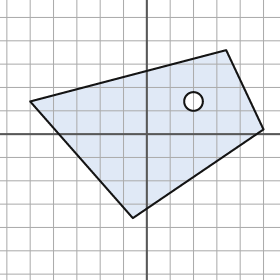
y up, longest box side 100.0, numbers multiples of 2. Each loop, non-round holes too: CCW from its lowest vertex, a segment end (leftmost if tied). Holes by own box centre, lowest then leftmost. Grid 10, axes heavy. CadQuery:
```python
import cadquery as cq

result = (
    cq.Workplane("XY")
    .moveTo(-6.0, -36.0)
    .lineTo(50.0, 2.0)
    .lineTo(34.0, 36.0)
    .lineTo(-50.0, 14.0)
    .close()
    .moveTo(20.0, 14.0)
    .circle(4.0)
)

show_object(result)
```